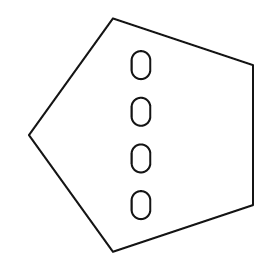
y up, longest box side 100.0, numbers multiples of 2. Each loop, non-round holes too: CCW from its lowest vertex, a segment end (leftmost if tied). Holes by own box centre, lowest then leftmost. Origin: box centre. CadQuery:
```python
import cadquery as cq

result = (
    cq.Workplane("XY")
    .moveTo(-12.0, -50.0)
    .lineTo(48.0, -30.0)
    .lineTo(48.0, 30.0)
    .lineTo(-12.0, 50.0)
    .lineTo(-48.0, 0.0)
    .close()
    .moveTo(-4.0, -32.0)
    .threePointArc((0.0, -36.0), (4.0, -32.0))
    .lineTo(4.0, -28.0)
    .threePointArc((0.0, -24.0), (-4.0, -28.0))
    .close()
    .moveTo(-4.0, -12.0)
    .threePointArc((0.0, -16.0), (4.0, -12.0))
    .lineTo(4.0, -8.0)
    .threePointArc((0.0, -4.0), (-4.0, -8.0))
    .close()
    .moveTo(-4.0, 8.0)
    .threePointArc((0.0, 4.0), (4.0, 8.0))
    .lineTo(4.0, 12.0)
    .threePointArc((0.0, 16.0), (-4.0, 12.0))
    .close()
    .moveTo(-4.0, 28.0)
    .threePointArc((0.0, 24.0), (4.0, 28.0))
    .lineTo(4.0, 32.0)
    .threePointArc((0.0, 36.0), (-4.0, 32.0))
    .close()
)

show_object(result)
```